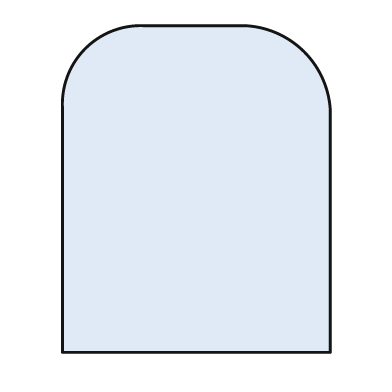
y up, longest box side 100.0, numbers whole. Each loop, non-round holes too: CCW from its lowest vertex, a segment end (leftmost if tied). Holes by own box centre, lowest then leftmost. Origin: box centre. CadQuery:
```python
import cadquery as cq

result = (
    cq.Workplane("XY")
    .moveTo(-41.0, -50.0)
    .lineTo(41.0, -50.0)
    .lineTo(41.0, 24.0)
    .threePointArc((33.0, 42.0), (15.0, 50.0))
    .lineTo(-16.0, 50.0)
    .threePointArc((-34.0, 43.0), (-41.0, 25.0))
    .close()
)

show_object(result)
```